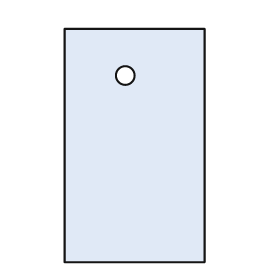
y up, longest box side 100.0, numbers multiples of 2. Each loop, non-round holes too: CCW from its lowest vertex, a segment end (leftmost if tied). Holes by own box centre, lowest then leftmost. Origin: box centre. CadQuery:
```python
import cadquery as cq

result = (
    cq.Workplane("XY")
    .moveTo(-30.0, -50.0)
    .lineTo(30.0, -50.0)
    .lineTo(30.0, 50.0)
    .lineTo(-30.0, 50.0)
    .close()
    .moveTo(-4.0, 30.0)
    .circle(4.0)
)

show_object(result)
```